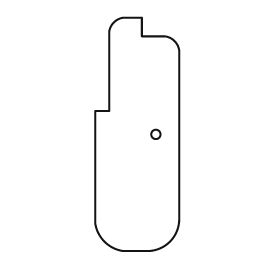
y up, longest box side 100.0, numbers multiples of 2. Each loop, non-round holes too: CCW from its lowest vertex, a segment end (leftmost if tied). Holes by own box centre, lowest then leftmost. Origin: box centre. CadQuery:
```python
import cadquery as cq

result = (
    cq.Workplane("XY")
    .moveTo(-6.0, -50.0)
    .lineTo(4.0, -50.0)
    .threePointArc((14.0, -46.0), (18.0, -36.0))
    .lineTo(18.0, 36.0)
    .threePointArc((16.0, 40.0), (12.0, 42.0))
    .lineTo(2.0, 42.0)
    .lineTo(2.0, 50.0)
    .lineTo(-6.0, 50.0)
    .threePointArc((-10.0, 48.0), (-12.0, 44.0))
    .lineTo(-12.0, 10.0)
    .lineTo(-18.0, 10.0)
    .lineTo(-18.0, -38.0)
    .threePointArc((-14.0, -46.0), (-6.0, -50.0))
    .close()
    .moveTo(8.0, 0.0)
    .circle(2.0)
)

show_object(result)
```